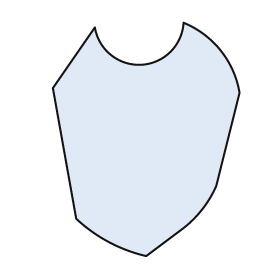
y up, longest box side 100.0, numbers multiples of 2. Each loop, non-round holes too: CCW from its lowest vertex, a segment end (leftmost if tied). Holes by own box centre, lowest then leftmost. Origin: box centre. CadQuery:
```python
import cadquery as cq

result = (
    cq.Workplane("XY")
    .moveTo(0.0, -50.0)
    .lineTo(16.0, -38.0)
    .threePointArc((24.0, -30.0), (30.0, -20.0))
    .lineTo(40.0, 20.0)
    .threePointArc((32.0, 38.0), (16.0, 50.0))
    .threePointArc((-2.0, 32.0), (-22.0, 48.0))
    .lineTo(-40.0, 22.0)
    .lineTo(-30.0, -34.0)
    .threePointArc((-16.0, -44.0), (0.0, -50.0))
    .close()
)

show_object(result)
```